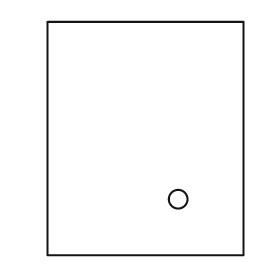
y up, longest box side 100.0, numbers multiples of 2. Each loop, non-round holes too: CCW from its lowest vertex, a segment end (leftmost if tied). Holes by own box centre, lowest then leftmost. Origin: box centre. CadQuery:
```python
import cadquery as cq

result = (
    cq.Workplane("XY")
    .moveTo(-42.0, -50.0)
    .lineTo(42.0, -50.0)
    .lineTo(42.0, 50.0)
    .lineTo(-42.0, 50.0)
    .close()
    .moveTo(14.0, -26.0)
    .circle(4.0)
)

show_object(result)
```